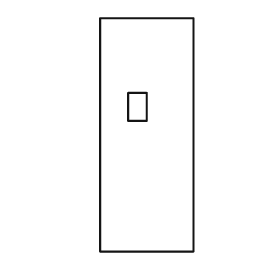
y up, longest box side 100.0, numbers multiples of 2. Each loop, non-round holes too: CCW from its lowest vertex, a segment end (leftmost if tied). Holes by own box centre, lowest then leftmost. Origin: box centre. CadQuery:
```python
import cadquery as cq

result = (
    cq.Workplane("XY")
    .moveTo(-20.0, -50.0)
    .lineTo(20.0, -50.0)
    .lineTo(20.0, 50.0)
    .lineTo(-20.0, 50.0)
    .close()
    .moveTo(-8.0, 6.0)
    .lineTo(0.0, 6.0)
    .lineTo(0.0, 18.0)
    .lineTo(-8.0, 18.0)
    .close()
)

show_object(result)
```